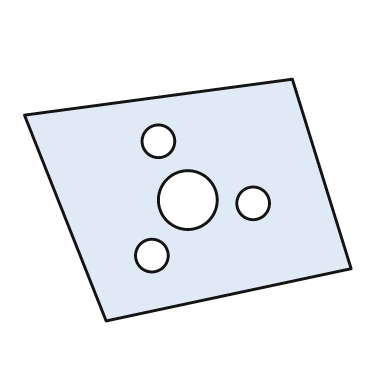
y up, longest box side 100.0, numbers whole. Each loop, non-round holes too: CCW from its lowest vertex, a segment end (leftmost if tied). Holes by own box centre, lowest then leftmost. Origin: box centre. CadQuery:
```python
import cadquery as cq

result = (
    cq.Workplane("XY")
    .moveTo(-25.0, -37.0)
    .lineTo(50.0, -21.0)
    .lineTo(32.0, 37.0)
    .lineTo(-50.0, 26.0)
    .close()
    .moveTo(-11.0, -17.0)
    .circle(5.0)
    .moveTo(20.0, -1.0)
    .circle(5.0)
    .moveTo(0.0, 0.0)
    .circle(9.0)
    .moveTo(-9.0, 18.0)
    .circle(5.0)
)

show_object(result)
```